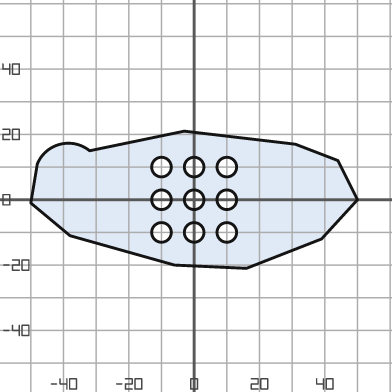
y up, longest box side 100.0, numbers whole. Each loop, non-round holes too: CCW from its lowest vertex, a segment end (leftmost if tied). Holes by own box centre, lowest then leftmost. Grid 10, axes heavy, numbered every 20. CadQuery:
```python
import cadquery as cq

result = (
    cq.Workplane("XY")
    .moveTo(16.0, -21.0)
    .lineTo(39.0, -12.0)
    .lineTo(50.0, 0.0)
    .lineTo(44.0, 12.0)
    .lineTo(31.0, 17.0)
    .lineTo(-3.0, 21.0)
    .lineTo(-32.0, 15.0)
    .threePointArc((-41.0, 17.0), (-48.0, 11.0))
    .lineTo(-50.0, -1.0)
    .lineTo(-38.0, -11.0)
    .lineTo(-6.0, -20.0)
    .close()
    .moveTo(-10.0, -10.0)
    .circle(3.0)
    .moveTo(0.0, -10.0)
    .circle(3.0)
    .moveTo(10.0, -10.0)
    .circle(3.0)
    .moveTo(-10.0, 0.0)
    .circle(3.0)
    .moveTo(0.0, 0.0)
    .circle(3.0)
    .moveTo(10.0, 0.0)
    .circle(3.0)
    .moveTo(-10.0, 10.0)
    .circle(3.0)
    .moveTo(0.0, 10.0)
    .circle(3.0)
    .moveTo(10.0, 10.0)
    .circle(3.0)
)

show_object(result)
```